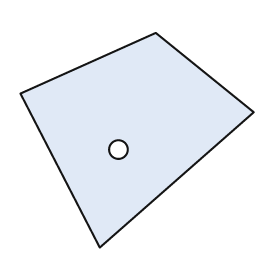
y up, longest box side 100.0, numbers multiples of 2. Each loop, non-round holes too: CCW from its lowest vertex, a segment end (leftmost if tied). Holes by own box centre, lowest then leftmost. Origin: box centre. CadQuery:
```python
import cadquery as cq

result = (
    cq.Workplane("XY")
    .moveTo(-16.0, -46.0)
    .lineTo(50.0, 12.0)
    .lineTo(8.0, 46.0)
    .lineTo(-50.0, 20.0)
    .close()
    .moveTo(-8.0, -4.0)
    .circle(4.0)
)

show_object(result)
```